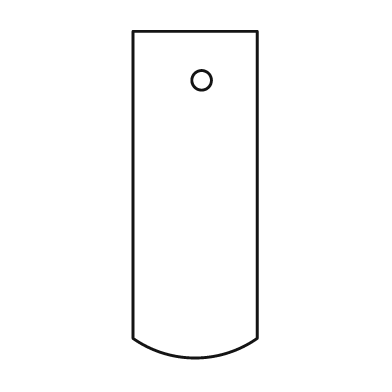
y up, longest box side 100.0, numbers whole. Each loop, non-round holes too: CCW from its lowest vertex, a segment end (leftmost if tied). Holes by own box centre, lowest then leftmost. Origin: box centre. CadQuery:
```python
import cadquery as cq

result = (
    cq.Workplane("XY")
    .moveTo(-19.0, -44.0)
    .threePointArc((0.0, -50.0), (19.0, -44.0))
    .lineTo(19.0, 50.0)
    .lineTo(-19.0, 50.0)
    .close()
    .moveTo(2.0, 35.0)
    .circle(3.0)
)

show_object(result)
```